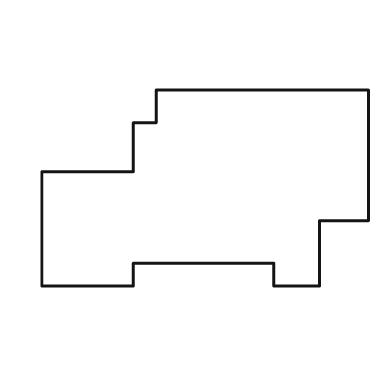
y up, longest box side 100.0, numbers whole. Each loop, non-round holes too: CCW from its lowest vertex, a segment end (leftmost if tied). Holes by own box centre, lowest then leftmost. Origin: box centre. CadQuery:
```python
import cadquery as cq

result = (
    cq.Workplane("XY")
    .moveTo(-50.0, -30.0)
    .lineTo(-22.0, -30.0)
    .lineTo(-22.0, -23.0)
    .lineTo(21.0, -23.0)
    .lineTo(21.0, -30.0)
    .lineTo(35.0, -30.0)
    .lineTo(35.0, -10.0)
    .lineTo(50.0, -10.0)
    .lineTo(50.0, 30.0)
    .lineTo(-15.0, 30.0)
    .lineTo(-15.0, 20.0)
    .lineTo(-22.0, 20.0)
    .lineTo(-22.0, 5.0)
    .lineTo(-50.0, 5.0)
    .close()
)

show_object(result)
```